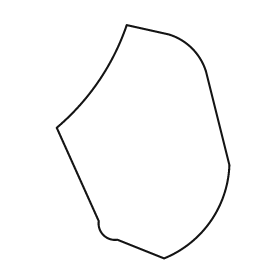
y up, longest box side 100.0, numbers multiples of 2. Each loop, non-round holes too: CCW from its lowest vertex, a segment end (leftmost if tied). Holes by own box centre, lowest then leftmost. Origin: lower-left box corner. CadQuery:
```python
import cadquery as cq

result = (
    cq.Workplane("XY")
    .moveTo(46.0, 0.0)
    .threePointArc((66.0, 16.0), (74.0, 40.0))
    .lineTo(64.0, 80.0)
    .threePointArc((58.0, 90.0), (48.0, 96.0))
    .lineTo(30.0, 100.0)
    .threePointArc((18.0, 76.0), (0.0, 56.0))
    .lineTo(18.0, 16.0)
    .threePointArc((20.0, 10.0), (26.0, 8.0))
    .close()
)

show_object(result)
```